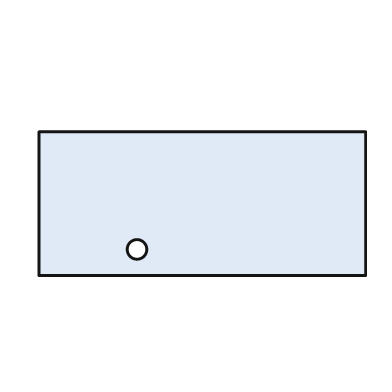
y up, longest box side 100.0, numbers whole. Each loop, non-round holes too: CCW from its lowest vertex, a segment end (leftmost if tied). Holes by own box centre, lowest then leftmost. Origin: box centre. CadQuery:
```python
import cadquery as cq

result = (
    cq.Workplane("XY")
    .moveTo(-50.0, -22.0)
    .lineTo(50.0, -22.0)
    .lineTo(50.0, 22.0)
    .lineTo(-50.0, 22.0)
    .close()
    .moveTo(-20.0, -14.0)
    .circle(3.0)
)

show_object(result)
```